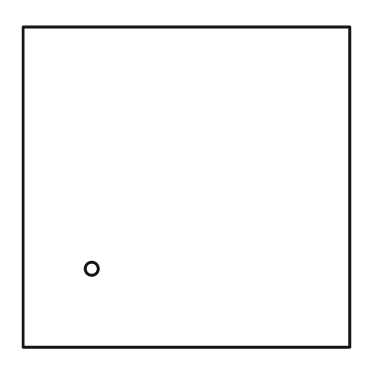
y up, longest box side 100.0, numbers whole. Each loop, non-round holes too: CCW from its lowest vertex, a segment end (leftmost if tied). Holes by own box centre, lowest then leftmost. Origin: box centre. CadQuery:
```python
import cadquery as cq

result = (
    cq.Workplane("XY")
    .moveTo(-50.0, -49.0)
    .lineTo(50.0, -49.0)
    .lineTo(50.0, 49.0)
    .lineTo(-50.0, 49.0)
    .close()
    .moveTo(-29.0, -25.0)
    .circle(2.0)
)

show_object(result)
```